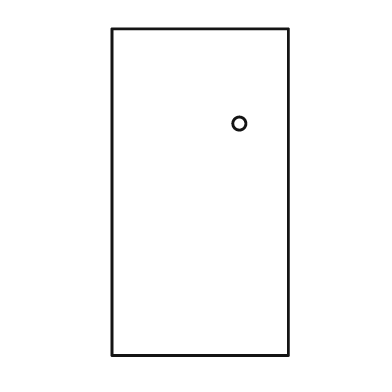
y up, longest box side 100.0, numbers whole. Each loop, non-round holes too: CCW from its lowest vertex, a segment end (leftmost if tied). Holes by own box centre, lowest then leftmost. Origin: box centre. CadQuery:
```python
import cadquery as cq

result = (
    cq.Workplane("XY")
    .moveTo(-27.0, -50.0)
    .lineTo(27.0, -50.0)
    .lineTo(27.0, 50.0)
    .lineTo(-27.0, 50.0)
    .close()
    .moveTo(12.0, 21.0)
    .circle(2.0)
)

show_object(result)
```